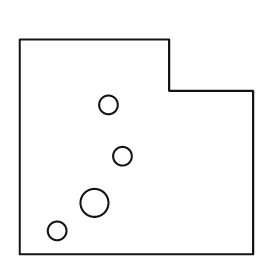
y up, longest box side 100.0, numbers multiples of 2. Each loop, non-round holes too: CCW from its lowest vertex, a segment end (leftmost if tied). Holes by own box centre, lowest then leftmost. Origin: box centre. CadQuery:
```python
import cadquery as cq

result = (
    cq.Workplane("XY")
    .moveTo(-50.0, -46.0)
    .lineTo(50.0, -46.0)
    .lineTo(50.0, 24.0)
    .lineTo(14.0, 24.0)
    .lineTo(14.0, 46.0)
    .lineTo(-50.0, 46.0)
    .close()
    .moveTo(-34.0, -36.0)
    .circle(4.0)
    .moveTo(-18.0, -24.0)
    .circle(6.0)
    .moveTo(-6.0, -4.0)
    .circle(4.0)
    .moveTo(-12.0, 18.0)
    .circle(4.0)
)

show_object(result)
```